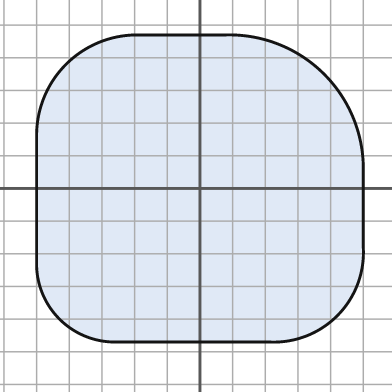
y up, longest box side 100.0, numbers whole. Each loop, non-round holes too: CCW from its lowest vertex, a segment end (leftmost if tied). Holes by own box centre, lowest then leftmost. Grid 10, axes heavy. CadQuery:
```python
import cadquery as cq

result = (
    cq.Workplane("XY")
    .moveTo(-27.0, -47.0)
    .lineTo(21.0, -47.0)
    .threePointArc((42.0, -39.0), (50.0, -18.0))
    .lineTo(50.0, 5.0)
    .threePointArc((38.0, 35.0), (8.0, 47.0))
    .lineTo(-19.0, 47.0)
    .threePointArc((-41.0, 38.0), (-50.0, 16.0))
    .lineTo(-50.0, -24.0)
    .threePointArc((-43.0, -40.0), (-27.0, -47.0))
    .close()
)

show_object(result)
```